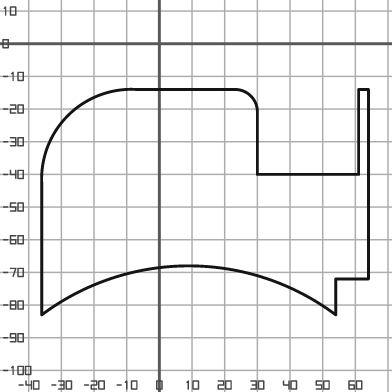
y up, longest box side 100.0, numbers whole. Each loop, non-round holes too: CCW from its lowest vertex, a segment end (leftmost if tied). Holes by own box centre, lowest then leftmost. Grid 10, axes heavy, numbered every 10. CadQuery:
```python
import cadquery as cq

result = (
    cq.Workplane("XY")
    .moveTo(-36.0, -83.0)
    .threePointArc((9.0, -68.0), (54.0, -83.0))
    .lineTo(54.0, -72.0)
    .lineTo(64.0, -72.0)
    .lineTo(64.0, -14.0)
    .lineTo(61.0, -14.0)
    .lineTo(61.0, -40.0)
    .lineTo(30.0, -40.0)
    .lineTo(30.0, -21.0)
    .threePointArc((28.0, -16.0), (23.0, -14.0))
    .lineTo(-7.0, -14.0)
    .threePointArc((-28.0, -22.0), (-36.0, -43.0))
    .close()
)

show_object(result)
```